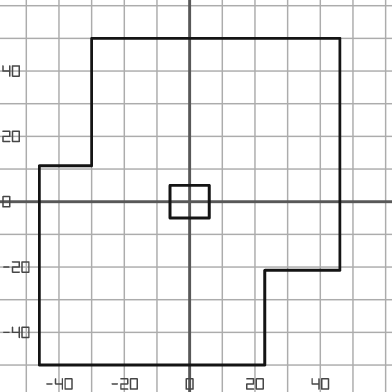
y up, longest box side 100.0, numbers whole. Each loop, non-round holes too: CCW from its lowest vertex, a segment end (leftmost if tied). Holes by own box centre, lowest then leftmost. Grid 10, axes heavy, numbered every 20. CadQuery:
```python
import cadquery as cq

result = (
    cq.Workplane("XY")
    .moveTo(-46.0, -50.0)
    .lineTo(23.0, -50.0)
    .lineTo(23.0, -21.0)
    .lineTo(46.0, -21.0)
    .lineTo(46.0, 50.0)
    .lineTo(-30.0, 50.0)
    .lineTo(-30.0, 11.0)
    .lineTo(-46.0, 11.0)
    .close()
    .moveTo(-6.0, -5.0)
    .lineTo(6.0, -5.0)
    .lineTo(6.0, 5.0)
    .lineTo(-6.0, 5.0)
    .close()
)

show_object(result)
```